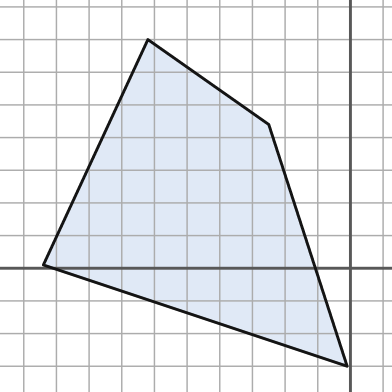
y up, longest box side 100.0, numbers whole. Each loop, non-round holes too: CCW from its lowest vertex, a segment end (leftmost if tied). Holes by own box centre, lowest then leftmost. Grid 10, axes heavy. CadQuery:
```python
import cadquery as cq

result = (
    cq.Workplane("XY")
    .moveTo(-1.0, -30.0)
    .lineTo(-25.0, 44.0)
    .lineTo(-62.0, 70.0)
    .lineTo(-94.0, 1.0)
    .close()
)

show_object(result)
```